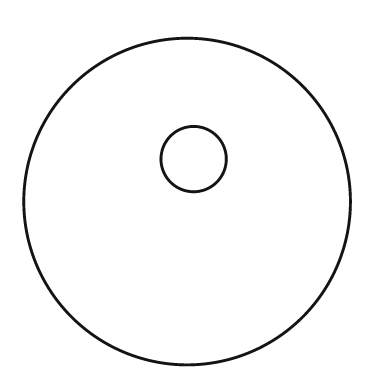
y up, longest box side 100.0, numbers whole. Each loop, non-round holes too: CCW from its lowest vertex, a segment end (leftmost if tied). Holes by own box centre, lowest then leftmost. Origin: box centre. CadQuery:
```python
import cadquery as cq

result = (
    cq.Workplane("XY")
    .moveTo(0.0, 0.0)
    .circle(50.0)
    .moveTo(2.0, 13.0)
    .circle(10.0)
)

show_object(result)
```